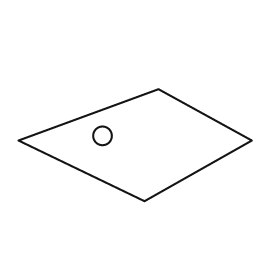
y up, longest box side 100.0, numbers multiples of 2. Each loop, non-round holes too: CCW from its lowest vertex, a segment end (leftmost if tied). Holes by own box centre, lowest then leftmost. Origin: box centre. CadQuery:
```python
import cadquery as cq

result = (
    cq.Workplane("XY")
    .moveTo(4.0, -24.0)
    .lineTo(50.0, 2.0)
    .lineTo(10.0, 24.0)
    .lineTo(-50.0, 2.0)
    .close()
    .moveTo(-14.0, 4.0)
    .circle(4.0)
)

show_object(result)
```